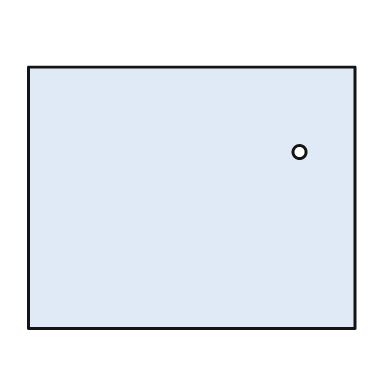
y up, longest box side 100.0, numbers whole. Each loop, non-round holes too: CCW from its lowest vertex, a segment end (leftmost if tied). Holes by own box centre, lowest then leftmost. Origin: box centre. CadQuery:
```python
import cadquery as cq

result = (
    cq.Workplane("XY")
    .moveTo(-50.0, -40.0)
    .lineTo(50.0, -40.0)
    .lineTo(50.0, 40.0)
    .lineTo(-50.0, 40.0)
    .close()
    .moveTo(33.0, 14.0)
    .circle(2.0)
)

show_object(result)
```